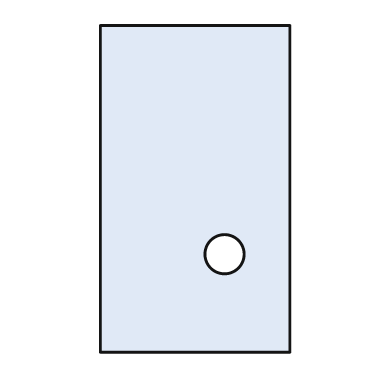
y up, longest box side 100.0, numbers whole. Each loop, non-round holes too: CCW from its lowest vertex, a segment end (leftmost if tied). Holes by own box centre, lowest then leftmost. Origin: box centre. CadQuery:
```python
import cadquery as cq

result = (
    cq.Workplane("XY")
    .moveTo(-29.0, -50.0)
    .lineTo(29.0, -50.0)
    .lineTo(29.0, 50.0)
    .lineTo(-29.0, 50.0)
    .close()
    .moveTo(9.0, -20.0)
    .circle(6.0)
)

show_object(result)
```